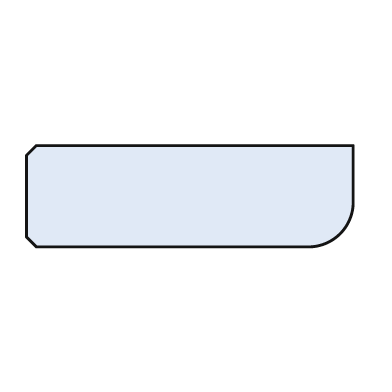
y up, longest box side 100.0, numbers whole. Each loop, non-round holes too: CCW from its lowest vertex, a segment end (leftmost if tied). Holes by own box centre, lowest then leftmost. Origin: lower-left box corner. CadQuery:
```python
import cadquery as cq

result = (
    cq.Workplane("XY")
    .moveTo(3.0, 0.0)
    .lineTo(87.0, 0.0)
    .threePointArc((96.0, 4.0), (100.0, 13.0))
    .lineTo(100.0, 31.0)
    .lineTo(3.0, 31.0)
    .lineTo(0.0, 28.0)
    .lineTo(0.0, 3.0)
    .close()
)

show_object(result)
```